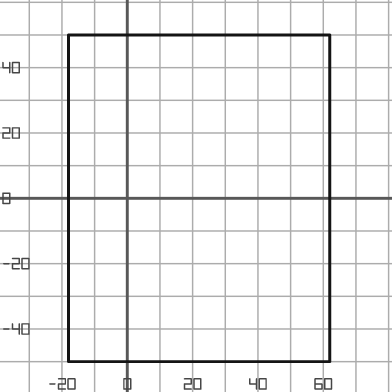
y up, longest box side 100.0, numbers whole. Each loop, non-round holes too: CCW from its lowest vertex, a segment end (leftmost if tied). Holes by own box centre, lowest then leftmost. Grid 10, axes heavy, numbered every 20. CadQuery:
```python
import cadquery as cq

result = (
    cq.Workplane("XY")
    .moveTo(-18.0, -50.0)
    .lineTo(62.0, -50.0)
    .lineTo(62.0, 50.0)
    .lineTo(-18.0, 50.0)
    .close()
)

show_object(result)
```